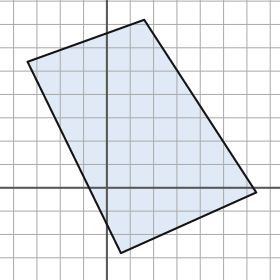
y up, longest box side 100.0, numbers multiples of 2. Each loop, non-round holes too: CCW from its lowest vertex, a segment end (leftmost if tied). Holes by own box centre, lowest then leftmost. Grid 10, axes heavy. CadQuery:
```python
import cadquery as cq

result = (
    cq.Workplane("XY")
    .moveTo(6.0, -28.0)
    .lineTo(64.0, -2.0)
    .lineTo(16.0, 72.0)
    .lineTo(-34.0, 54.0)
    .close()
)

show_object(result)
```